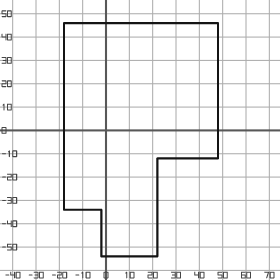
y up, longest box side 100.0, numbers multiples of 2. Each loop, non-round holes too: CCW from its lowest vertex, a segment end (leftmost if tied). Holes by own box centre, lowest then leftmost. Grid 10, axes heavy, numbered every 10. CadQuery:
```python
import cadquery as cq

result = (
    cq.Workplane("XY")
    .moveTo(-2.0, -54.0)
    .lineTo(22.0, -54.0)
    .lineTo(22.0, -12.0)
    .lineTo(48.0, -12.0)
    .lineTo(48.0, 46.0)
    .lineTo(-18.0, 46.0)
    .lineTo(-18.0, -34.0)
    .lineTo(-2.0, -34.0)
    .close()
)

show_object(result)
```